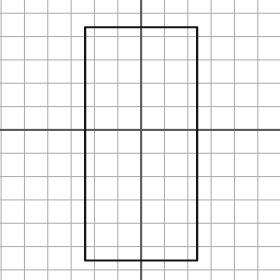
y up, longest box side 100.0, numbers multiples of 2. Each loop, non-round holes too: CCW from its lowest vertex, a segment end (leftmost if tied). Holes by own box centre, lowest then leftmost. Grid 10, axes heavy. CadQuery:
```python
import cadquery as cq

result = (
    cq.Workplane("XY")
    .moveTo(-24.0, -56.0)
    .lineTo(24.0, -56.0)
    .lineTo(24.0, 44.0)
    .lineTo(-24.0, 44.0)
    .close()
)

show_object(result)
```